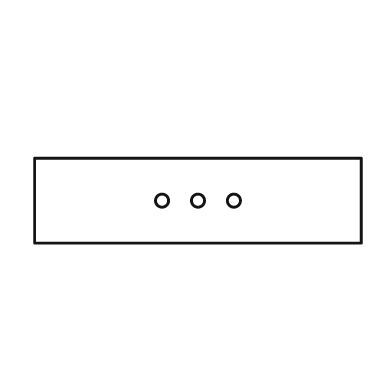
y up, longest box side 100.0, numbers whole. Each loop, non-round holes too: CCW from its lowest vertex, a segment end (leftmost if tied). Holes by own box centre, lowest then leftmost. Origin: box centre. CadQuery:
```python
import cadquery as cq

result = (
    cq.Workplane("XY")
    .moveTo(-50.0, -13.0)
    .lineTo(50.0, -13.0)
    .lineTo(50.0, 13.0)
    .lineTo(-50.0, 13.0)
    .close()
    .moveTo(-11.0, 0.0)
    .circle(2.0)
    .moveTo(0.0, 0.0)
    .circle(2.0)
    .moveTo(11.0, 0.0)
    .circle(2.0)
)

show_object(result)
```